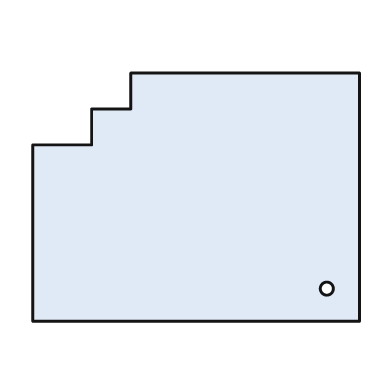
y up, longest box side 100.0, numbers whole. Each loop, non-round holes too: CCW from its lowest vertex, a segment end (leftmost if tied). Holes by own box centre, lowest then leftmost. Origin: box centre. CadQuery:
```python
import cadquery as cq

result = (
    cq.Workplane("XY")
    .moveTo(-50.0, -38.0)
    .lineTo(50.0, -38.0)
    .lineTo(50.0, 38.0)
    .lineTo(-20.0, 38.0)
    .lineTo(-20.0, 27.0)
    .lineTo(-32.0, 27.0)
    .lineTo(-32.0, 16.0)
    .lineTo(-50.0, 16.0)
    .close()
    .moveTo(40.0, -28.0)
    .circle(2.0)
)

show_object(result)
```